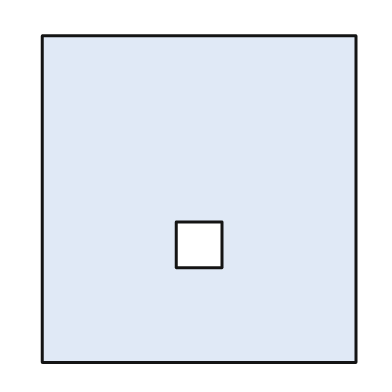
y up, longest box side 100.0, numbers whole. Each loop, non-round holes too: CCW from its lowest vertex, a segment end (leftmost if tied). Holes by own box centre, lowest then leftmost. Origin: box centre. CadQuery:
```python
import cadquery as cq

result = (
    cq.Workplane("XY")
    .moveTo(-48.0, -50.0)
    .lineTo(48.0, -50.0)
    .lineTo(48.0, 50.0)
    .lineTo(-48.0, 50.0)
    .close()
    .moveTo(-7.0, -21.0)
    .lineTo(7.0, -21.0)
    .lineTo(7.0, -7.0)
    .lineTo(-7.0, -7.0)
    .close()
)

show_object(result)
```